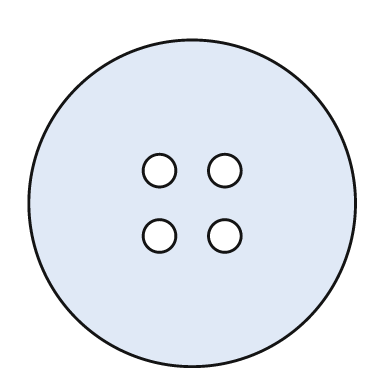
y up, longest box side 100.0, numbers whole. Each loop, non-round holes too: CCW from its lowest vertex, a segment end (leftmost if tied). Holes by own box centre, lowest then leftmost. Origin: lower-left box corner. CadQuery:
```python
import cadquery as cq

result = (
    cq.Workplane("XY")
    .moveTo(50.0, 50.0)
    .circle(50.0)
    .moveTo(40.0, 40.0)
    .circle(5.0)
    .moveTo(60.0, 40.0)
    .circle(5.0)
    .moveTo(40.0, 60.0)
    .circle(5.0)
    .moveTo(60.0, 60.0)
    .circle(5.0)
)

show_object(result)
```